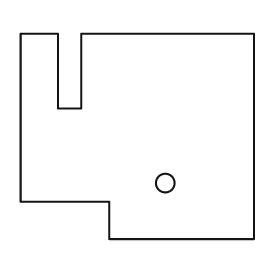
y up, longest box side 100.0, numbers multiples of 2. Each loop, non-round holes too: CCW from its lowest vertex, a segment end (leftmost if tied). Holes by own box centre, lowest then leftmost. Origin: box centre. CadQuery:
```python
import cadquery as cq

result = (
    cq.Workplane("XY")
    .moveTo(-12.0, -44.0)
    .lineTo(50.0, -44.0)
    .lineTo(50.0, 44.0)
    .lineTo(-24.0, 44.0)
    .lineTo(-24.0, 12.0)
    .lineTo(-34.0, 12.0)
    .lineTo(-34.0, 44.0)
    .lineTo(-50.0, 44.0)
    .lineTo(-50.0, -28.0)
    .lineTo(-12.0, -28.0)
    .close()
    .moveTo(12.0, -20.0)
    .circle(4.0)
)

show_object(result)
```